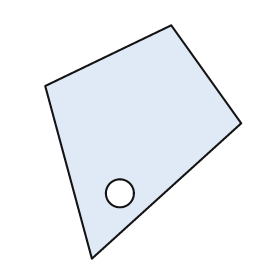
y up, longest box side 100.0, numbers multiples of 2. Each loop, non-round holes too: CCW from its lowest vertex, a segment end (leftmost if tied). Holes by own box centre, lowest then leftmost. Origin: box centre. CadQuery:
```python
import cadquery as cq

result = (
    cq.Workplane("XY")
    .moveTo(-22.0, -50.0)
    .lineTo(42.0, 8.0)
    .lineTo(12.0, 50.0)
    .lineTo(-42.0, 24.0)
    .close()
    .moveTo(-10.0, -22.0)
    .circle(6.0)
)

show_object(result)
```